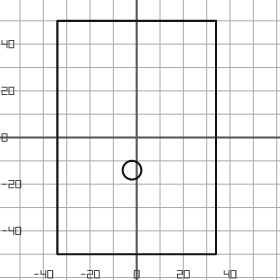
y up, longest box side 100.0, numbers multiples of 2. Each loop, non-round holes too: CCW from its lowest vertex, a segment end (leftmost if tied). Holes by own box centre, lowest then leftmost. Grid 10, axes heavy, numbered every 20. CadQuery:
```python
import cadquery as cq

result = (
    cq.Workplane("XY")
    .moveTo(-34.0, -50.0)
    .lineTo(34.0, -50.0)
    .lineTo(34.0, 50.0)
    .lineTo(-34.0, 50.0)
    .close()
    .moveTo(-2.0, -14.0)
    .circle(4.0)
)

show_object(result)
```